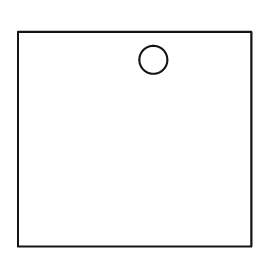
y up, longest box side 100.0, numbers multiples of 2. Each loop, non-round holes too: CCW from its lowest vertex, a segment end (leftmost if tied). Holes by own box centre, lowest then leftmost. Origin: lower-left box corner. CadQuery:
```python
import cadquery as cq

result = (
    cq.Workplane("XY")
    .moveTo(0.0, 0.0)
    .lineTo(100.0, 0.0)
    .lineTo(100.0, 92.0)
    .lineTo(0.0, 92.0)
    .close()
    .moveTo(58.0, 80.0)
    .circle(6.0)
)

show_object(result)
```